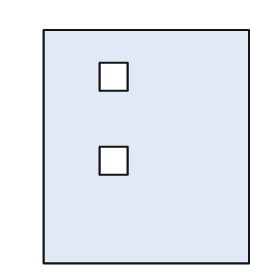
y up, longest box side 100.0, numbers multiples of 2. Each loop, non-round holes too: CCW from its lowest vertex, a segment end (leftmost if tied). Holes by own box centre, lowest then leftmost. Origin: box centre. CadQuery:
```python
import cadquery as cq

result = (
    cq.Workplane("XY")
    .moveTo(-44.0, -50.0)
    .lineTo(44.0, -50.0)
    .lineTo(44.0, 50.0)
    .lineTo(-44.0, 50.0)
    .close()
    .moveTo(-20.0, -12.0)
    .lineTo(-8.0, -12.0)
    .lineTo(-8.0, 0.0)
    .lineTo(-20.0, 0.0)
    .close()
    .moveTo(-20.0, 24.0)
    .lineTo(-8.0, 24.0)
    .lineTo(-8.0, 36.0)
    .lineTo(-20.0, 36.0)
    .close()
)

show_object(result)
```